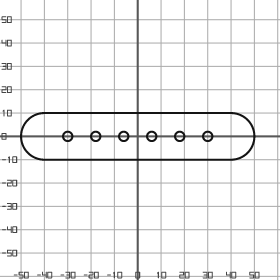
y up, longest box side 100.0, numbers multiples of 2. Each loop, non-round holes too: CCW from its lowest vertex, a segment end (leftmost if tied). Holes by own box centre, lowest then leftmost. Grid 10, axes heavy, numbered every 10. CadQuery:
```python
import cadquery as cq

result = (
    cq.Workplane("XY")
    .moveTo(-40.0, -10.0)
    .lineTo(40.0, -10.0)
    .threePointArc((50.0, 0.0), (40.0, 10.0))
    .lineTo(-40.0, 10.0)
    .threePointArc((-50.0, 0.0), (-40.0, -10.0))
    .close()
    .moveTo(-30.0, 0.0)
    .circle(2.0)
    .moveTo(-18.0, 0.0)
    .circle(2.0)
    .moveTo(-6.0, 0.0)
    .circle(2.0)
    .moveTo(6.0, 0.0)
    .circle(2.0)
    .moveTo(18.0, 0.0)
    .circle(2.0)
    .moveTo(30.0, 0.0)
    .circle(2.0)
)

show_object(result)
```